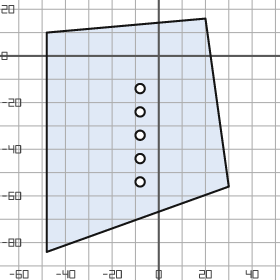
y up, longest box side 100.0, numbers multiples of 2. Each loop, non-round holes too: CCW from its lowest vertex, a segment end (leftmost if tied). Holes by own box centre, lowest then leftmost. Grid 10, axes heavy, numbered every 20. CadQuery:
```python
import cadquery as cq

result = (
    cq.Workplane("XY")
    .moveTo(-48.0, -84.0)
    .lineTo(30.0, -56.0)
    .lineTo(20.0, 16.0)
    .lineTo(-48.0, 10.0)
    .close()
    .moveTo(-8.0, -54.0)
    .circle(2.0)
    .moveTo(-8.0, -44.0)
    .circle(2.0)
    .moveTo(-8.0, -34.0)
    .circle(2.0)
    .moveTo(-8.0, -24.0)
    .circle(2.0)
    .moveTo(-8.0, -14.0)
    .circle(2.0)
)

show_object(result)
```